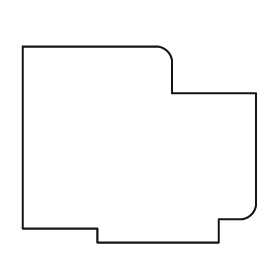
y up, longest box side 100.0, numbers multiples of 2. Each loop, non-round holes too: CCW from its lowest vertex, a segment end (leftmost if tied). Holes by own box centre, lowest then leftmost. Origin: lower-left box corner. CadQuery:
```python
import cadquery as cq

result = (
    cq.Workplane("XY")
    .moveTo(32.0, 0.0)
    .lineTo(84.0, 0.0)
    .lineTo(84.0, 10.0)
    .lineTo(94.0, 10.0)
    .threePointArc((98.0, 12.0), (100.0, 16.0))
    .lineTo(100.0, 64.0)
    .lineTo(64.0, 64.0)
    .lineTo(64.0, 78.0)
    .threePointArc((62.0, 82.0), (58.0, 84.0))
    .lineTo(0.0, 84.0)
    .lineTo(0.0, 6.0)
    .lineTo(32.0, 6.0)
    .close()
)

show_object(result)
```